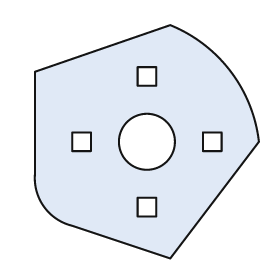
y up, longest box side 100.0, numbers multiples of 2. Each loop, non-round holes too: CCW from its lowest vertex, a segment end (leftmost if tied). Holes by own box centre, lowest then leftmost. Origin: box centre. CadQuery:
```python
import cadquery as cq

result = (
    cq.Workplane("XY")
    .moveTo(10.0, -50.0)
    .lineTo(48.0, 0.0)
    .threePointArc((36.0, 30.0), (10.0, 50.0))
    .lineTo(-48.0, 30.0)
    .lineTo(-48.0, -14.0)
    .threePointArc((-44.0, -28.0), (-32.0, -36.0))
    .close()
    .moveTo(-4.0, -32.0)
    .lineTo(4.0, -32.0)
    .lineTo(4.0, -24.0)
    .lineTo(-4.0, -24.0)
    .close()
    .moveTo(-32.0, -4.0)
    .lineTo(-24.0, -4.0)
    .lineTo(-24.0, 4.0)
    .lineTo(-32.0, 4.0)
    .close()
    .moveTo(0.0, 0.0)
    .circle(12.0)
    .moveTo(24.0, -4.0)
    .lineTo(32.0, -4.0)
    .lineTo(32.0, 4.0)
    .lineTo(24.0, 4.0)
    .close()
    .moveTo(-4.0, 24.0)
    .lineTo(4.0, 24.0)
    .lineTo(4.0, 32.0)
    .lineTo(-4.0, 32.0)
    .close()
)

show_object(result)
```